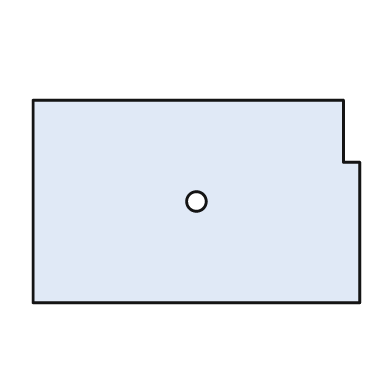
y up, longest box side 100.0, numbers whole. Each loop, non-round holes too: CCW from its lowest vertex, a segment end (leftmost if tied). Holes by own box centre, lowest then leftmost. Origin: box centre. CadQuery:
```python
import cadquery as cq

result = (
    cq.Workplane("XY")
    .moveTo(-50.0, -31.0)
    .lineTo(50.0, -31.0)
    .lineTo(50.0, 12.0)
    .lineTo(45.0, 12.0)
    .lineTo(45.0, 31.0)
    .lineTo(-50.0, 31.0)
    .close()
    .moveTo(0.0, 0.0)
    .circle(3.0)
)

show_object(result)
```